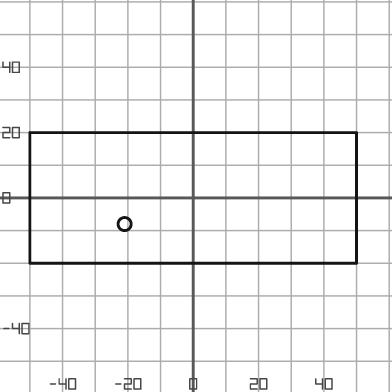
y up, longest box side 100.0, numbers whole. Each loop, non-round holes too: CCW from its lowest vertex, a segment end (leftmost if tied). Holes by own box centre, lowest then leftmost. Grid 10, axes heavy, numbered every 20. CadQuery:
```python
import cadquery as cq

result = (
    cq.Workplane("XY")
    .moveTo(-50.0, -20.0)
    .lineTo(50.0, -20.0)
    .lineTo(50.0, 20.0)
    .lineTo(-50.0, 20.0)
    .close()
    .moveTo(-21.0, -8.0)
    .circle(2.0)
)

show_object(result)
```